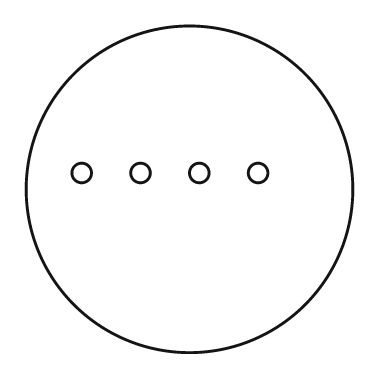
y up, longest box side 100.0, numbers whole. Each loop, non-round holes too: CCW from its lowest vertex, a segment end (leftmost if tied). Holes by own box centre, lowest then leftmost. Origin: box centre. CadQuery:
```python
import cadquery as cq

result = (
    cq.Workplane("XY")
    .moveTo(0.0, 0.0)
    .circle(50.0)
    .moveTo(-33.0, 5.0)
    .circle(3.0)
    .moveTo(-15.0, 5.0)
    .circle(3.0)
    .moveTo(3.0, 5.0)
    .circle(3.0)
    .moveTo(21.0, 5.0)
    .circle(3.0)
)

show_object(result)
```